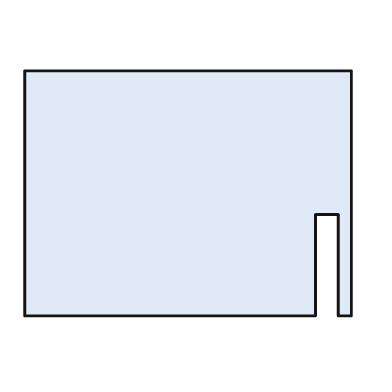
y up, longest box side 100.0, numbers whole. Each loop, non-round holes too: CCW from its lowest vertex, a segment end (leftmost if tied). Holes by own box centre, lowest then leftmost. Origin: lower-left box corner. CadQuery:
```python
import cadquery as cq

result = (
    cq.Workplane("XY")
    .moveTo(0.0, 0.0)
    .lineTo(89.0, 0.0)
    .lineTo(89.0, 31.0)
    .lineTo(96.0, 31.0)
    .lineTo(96.0, 0.0)
    .lineTo(100.0, 0.0)
    .lineTo(100.0, 75.0)
    .lineTo(0.0, 75.0)
    .close()
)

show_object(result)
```